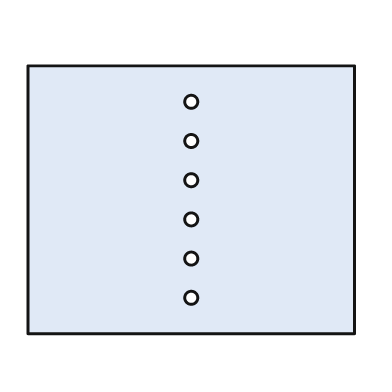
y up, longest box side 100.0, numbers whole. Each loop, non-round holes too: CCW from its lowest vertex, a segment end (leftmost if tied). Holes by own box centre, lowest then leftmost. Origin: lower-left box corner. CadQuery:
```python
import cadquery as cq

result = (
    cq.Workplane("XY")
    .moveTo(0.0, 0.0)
    .lineTo(100.0, 0.0)
    .lineTo(100.0, 82.0)
    .lineTo(0.0, 82.0)
    .close()
    .moveTo(50.0, 11.0)
    .circle(2.0)
    .moveTo(50.0, 23.0)
    .circle(2.0)
    .moveTo(50.0, 35.0)
    .circle(2.0)
    .moveTo(50.0, 47.0)
    .circle(2.0)
    .moveTo(50.0, 59.0)
    .circle(2.0)
    .moveTo(50.0, 71.0)
    .circle(2.0)
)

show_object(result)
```